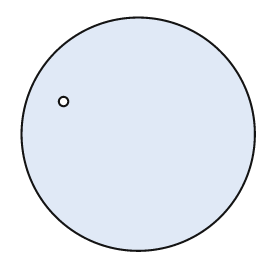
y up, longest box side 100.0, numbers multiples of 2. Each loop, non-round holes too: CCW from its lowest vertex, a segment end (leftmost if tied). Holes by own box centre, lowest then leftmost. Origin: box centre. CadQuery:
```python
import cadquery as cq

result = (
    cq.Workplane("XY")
    .moveTo(0.0, 0.0)
    .circle(50.0)
    .moveTo(-32.0, 14.0)
    .circle(2.0)
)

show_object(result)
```